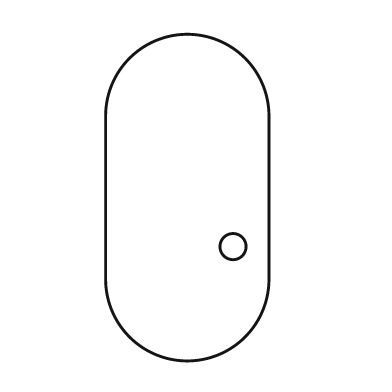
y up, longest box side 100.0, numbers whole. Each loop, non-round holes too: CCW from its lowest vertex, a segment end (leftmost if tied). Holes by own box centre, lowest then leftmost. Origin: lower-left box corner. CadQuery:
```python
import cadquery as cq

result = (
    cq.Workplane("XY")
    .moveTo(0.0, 25.0)
    .threePointArc((25.0, 0.0), (50.0, 25.0))
    .lineTo(50.0, 75.0)
    .threePointArc((25.0, 100.0), (0.0, 75.0))
    .close()
    .moveTo(39.0, 35.0)
    .circle(4.0)
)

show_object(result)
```